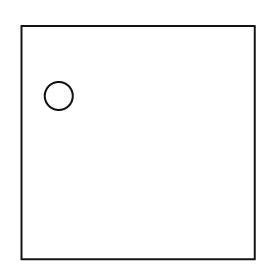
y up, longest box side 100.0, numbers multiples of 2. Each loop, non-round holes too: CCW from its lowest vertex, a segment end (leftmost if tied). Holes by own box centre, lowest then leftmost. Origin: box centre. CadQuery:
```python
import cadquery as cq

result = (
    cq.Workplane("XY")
    .moveTo(-50.0, -50.0)
    .lineTo(50.0, -50.0)
    .lineTo(50.0, 50.0)
    .lineTo(-50.0, 50.0)
    .close()
    .moveTo(-34.0, 20.0)
    .circle(6.0)
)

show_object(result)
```